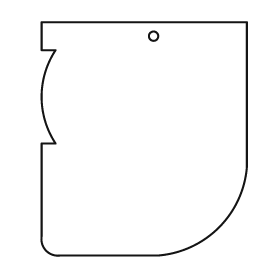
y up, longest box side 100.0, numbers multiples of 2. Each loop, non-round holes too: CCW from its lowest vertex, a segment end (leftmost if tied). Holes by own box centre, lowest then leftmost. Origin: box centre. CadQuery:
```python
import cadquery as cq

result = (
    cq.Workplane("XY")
    .moveTo(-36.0, -50.0)
    .lineTo(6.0, -50.0)
    .threePointArc((32.0, -38.0), (44.0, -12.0))
    .lineTo(44.0, 50.0)
    .lineTo(-44.0, 50.0)
    .lineTo(-44.0, 38.0)
    .lineTo(-38.0, 38.0)
    .threePointArc((-44.0, 18.0), (-38.0, -2.0))
    .lineTo(-44.0, -2.0)
    .lineTo(-44.0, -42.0)
    .threePointArc((-42.0, -48.0), (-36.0, -50.0))
    .close()
    .moveTo(4.0, 44.0)
    .circle(2.0)
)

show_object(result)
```